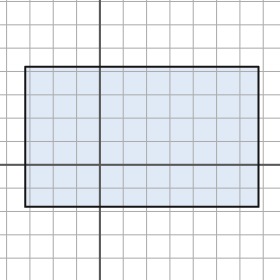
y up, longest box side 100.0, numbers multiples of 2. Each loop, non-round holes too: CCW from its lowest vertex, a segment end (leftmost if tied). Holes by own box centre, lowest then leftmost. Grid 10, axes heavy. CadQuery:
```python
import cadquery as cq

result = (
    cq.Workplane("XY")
    .moveTo(-32.0, -18.0)
    .lineTo(68.0, -18.0)
    .lineTo(68.0, 42.0)
    .lineTo(-32.0, 42.0)
    .close()
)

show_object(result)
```